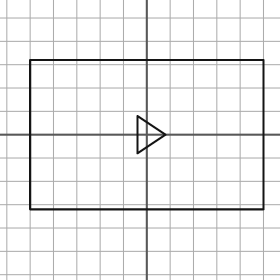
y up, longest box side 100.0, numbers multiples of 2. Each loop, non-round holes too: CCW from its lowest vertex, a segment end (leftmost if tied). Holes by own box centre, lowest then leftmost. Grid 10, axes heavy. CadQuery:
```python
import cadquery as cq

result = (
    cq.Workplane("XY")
    .moveTo(-50.0, -32.0)
    .lineTo(50.0, -32.0)
    .lineTo(50.0, 32.0)
    .lineTo(-50.0, 32.0)
    .close()
    .moveTo(-4.0, -8.0)
    .lineTo(8.0, 0.0)
    .lineTo(-4.0, 8.0)
    .close()
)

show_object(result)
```